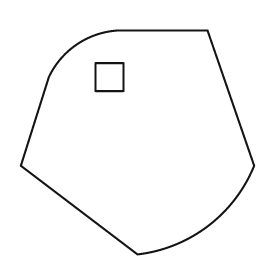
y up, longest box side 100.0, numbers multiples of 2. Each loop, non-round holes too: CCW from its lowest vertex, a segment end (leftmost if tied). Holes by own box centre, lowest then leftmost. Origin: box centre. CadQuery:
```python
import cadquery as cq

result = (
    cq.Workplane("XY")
    .moveTo(0.0, -48.0)
    .threePointArc((30.0, -36.0), (50.0, -10.0))
    .lineTo(30.0, 48.0)
    .lineTo(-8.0, 48.0)
    .threePointArc((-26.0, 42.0), (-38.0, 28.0))
    .lineTo(-50.0, -10.0)
    .close()
    .moveTo(-18.0, 22.0)
    .lineTo(-6.0, 22.0)
    .lineTo(-6.0, 34.0)
    .lineTo(-18.0, 34.0)
    .close()
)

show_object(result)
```